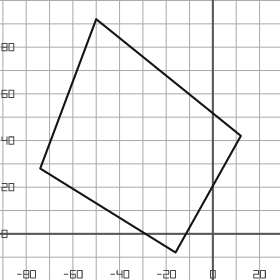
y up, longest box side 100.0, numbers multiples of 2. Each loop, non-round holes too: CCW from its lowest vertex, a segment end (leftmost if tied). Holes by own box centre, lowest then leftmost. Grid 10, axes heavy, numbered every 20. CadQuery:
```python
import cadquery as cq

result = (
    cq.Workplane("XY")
    .moveTo(-16.0, -8.0)
    .lineTo(12.0, 42.0)
    .lineTo(-50.0, 92.0)
    .lineTo(-74.0, 28.0)
    .close()
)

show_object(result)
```